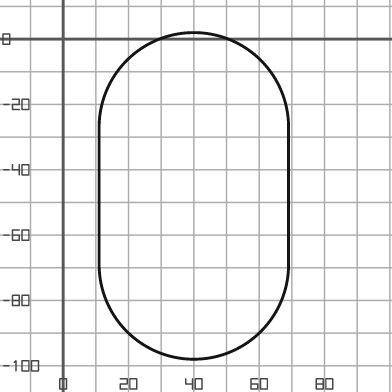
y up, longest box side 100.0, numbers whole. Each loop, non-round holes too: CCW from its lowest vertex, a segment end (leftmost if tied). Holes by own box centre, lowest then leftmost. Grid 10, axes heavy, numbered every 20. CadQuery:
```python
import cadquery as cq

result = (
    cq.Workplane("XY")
    .moveTo(11.0, -69.0)
    .threePointArc((40.0, -98.0), (69.0, -69.0))
    .lineTo(69.0, -27.0)
    .threePointArc((40.0, 2.0), (11.0, -27.0))
    .close()
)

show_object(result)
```